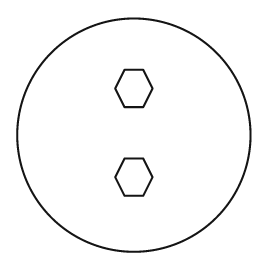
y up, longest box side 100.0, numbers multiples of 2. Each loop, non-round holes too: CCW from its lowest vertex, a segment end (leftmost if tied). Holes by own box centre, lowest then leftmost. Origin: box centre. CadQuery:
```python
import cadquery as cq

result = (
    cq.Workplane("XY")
    .moveTo(0.0, 0.0)
    .circle(50.0)
    .moveTo(-4.0, -26.0)
    .lineTo(4.0, -26.0)
    .lineTo(8.0, -18.0)
    .lineTo(4.0, -10.0)
    .lineTo(-4.0, -10.0)
    .lineTo(-8.0, -18.0)
    .close()
    .moveTo(-4.0, 12.0)
    .lineTo(4.0, 12.0)
    .lineTo(8.0, 20.0)
    .lineTo(4.0, 28.0)
    .lineTo(-4.0, 28.0)
    .lineTo(-8.0, 20.0)
    .close()
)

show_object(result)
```